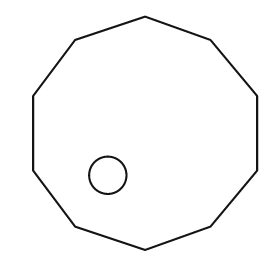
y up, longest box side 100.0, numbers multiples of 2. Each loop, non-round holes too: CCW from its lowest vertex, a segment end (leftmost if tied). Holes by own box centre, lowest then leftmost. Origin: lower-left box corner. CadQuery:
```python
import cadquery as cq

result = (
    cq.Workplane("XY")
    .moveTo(48.0, 0.0)
    .lineTo(76.0, 10.0)
    .lineTo(96.0, 34.0)
    .lineTo(96.0, 66.0)
    .lineTo(76.0, 90.0)
    .lineTo(48.0, 100.0)
    .lineTo(18.0, 90.0)
    .lineTo(0.0, 66.0)
    .lineTo(0.0, 34.0)
    .lineTo(18.0, 10.0)
    .close()
    .moveTo(32.0, 32.0)
    .circle(8.0)
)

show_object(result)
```